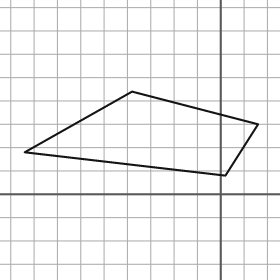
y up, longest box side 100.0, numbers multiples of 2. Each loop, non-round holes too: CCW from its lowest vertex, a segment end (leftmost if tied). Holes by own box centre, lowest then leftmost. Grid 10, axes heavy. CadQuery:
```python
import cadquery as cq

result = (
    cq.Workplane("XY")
    .moveTo(2.0, 8.0)
    .lineTo(16.0, 30.0)
    .lineTo(-38.0, 44.0)
    .lineTo(-84.0, 18.0)
    .close()
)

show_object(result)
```